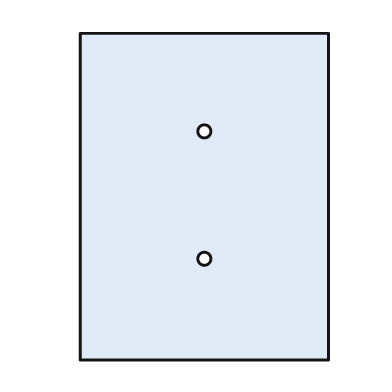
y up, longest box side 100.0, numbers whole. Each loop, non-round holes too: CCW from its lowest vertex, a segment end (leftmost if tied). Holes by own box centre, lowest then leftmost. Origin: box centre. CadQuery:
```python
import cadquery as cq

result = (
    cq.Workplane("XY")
    .moveTo(-38.0, -50.0)
    .lineTo(38.0, -50.0)
    .lineTo(38.0, 50.0)
    .lineTo(-38.0, 50.0)
    .close()
    .moveTo(0.0, -19.0)
    .circle(2.0)
    .moveTo(0.0, 20.0)
    .circle(2.0)
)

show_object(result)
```